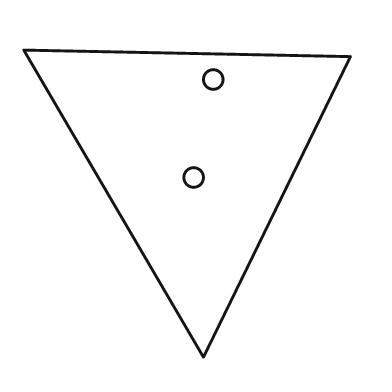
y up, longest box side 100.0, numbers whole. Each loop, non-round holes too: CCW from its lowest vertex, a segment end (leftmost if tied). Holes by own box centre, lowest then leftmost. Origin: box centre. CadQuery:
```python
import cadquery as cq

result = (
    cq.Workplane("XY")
    .moveTo(5.0, -47.0)
    .lineTo(50.0, 45.0)
    .lineTo(-50.0, 47.0)
    .close()
    .moveTo(2.0, 8.0)
    .circle(3.0)
    .moveTo(8.0, 38.0)
    .circle(3.0)
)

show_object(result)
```